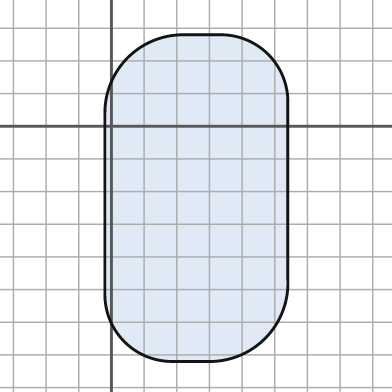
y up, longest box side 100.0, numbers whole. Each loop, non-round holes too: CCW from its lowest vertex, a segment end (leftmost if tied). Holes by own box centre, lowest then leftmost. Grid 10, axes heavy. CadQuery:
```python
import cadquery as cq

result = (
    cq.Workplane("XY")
    .moveTo(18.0, -72.0)
    .lineTo(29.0, -72.0)
    .threePointArc((47.0, -65.0), (54.0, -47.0))
    .lineTo(54.0, 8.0)
    .threePointArc((48.0, 22.0), (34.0, 28.0))
    .lineTo(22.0, 28.0)
    .threePointArc((5.0, 21.0), (-2.0, 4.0))
    .lineTo(-2.0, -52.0)
    .threePointArc((4.0, -66.0), (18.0, -72.0))
    .close()
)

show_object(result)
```